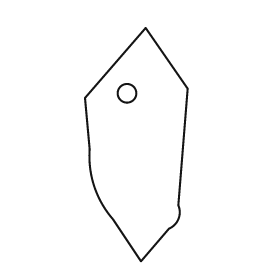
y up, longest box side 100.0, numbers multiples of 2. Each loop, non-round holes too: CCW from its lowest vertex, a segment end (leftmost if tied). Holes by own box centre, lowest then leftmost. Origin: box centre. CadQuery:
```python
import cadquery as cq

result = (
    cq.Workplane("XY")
    .moveTo(2.0, -50.0)
    .lineTo(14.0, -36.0)
    .threePointArc((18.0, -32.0), (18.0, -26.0))
    .lineTo(22.0, 24.0)
    .lineTo(4.0, 50.0)
    .lineTo(-22.0, 20.0)
    .lineTo(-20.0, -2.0)
    .threePointArc((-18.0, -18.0), (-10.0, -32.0))
    .close()
    .moveTo(-4.0, 22.0)
    .circle(4.0)
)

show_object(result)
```